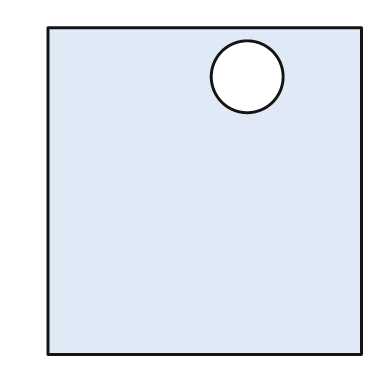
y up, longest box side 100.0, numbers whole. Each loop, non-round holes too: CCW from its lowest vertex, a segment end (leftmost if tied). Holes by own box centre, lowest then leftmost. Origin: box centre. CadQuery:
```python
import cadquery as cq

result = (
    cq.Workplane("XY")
    .moveTo(-48.0, -50.0)
    .lineTo(48.0, -50.0)
    .lineTo(48.0, 50.0)
    .lineTo(-48.0, 50.0)
    .close()
    .moveTo(13.0, 35.0)
    .circle(11.0)
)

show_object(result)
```